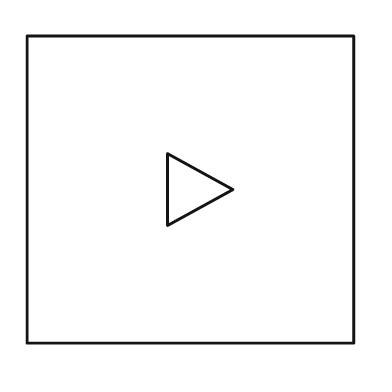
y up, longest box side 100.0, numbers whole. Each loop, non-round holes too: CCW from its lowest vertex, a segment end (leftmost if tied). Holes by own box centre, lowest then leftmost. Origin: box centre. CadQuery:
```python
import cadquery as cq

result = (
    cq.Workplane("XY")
    .moveTo(-50.0, -47.0)
    .lineTo(50.0, -47.0)
    .lineTo(50.0, 47.0)
    .lineTo(-50.0, 47.0)
    .close()
    .moveTo(-7.0, -11.0)
    .lineTo(13.0, 0.0)
    .lineTo(-7.0, 11.0)
    .close()
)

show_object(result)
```